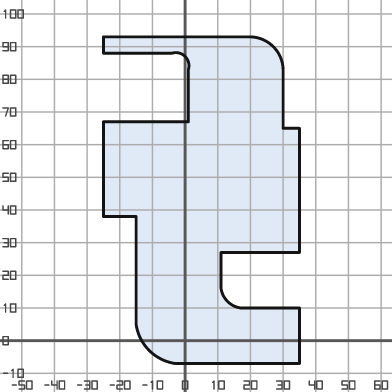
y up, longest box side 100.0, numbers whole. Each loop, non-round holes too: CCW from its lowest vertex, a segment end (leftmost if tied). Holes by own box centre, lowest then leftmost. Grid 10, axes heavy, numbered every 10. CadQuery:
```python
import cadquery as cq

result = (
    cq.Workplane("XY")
    .moveTo(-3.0, -7.0)
    .lineTo(35.0, -7.0)
    .lineTo(35.0, 10.0)
    .lineTo(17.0, 10.0)
    .threePointArc((13.0, 12.0), (11.0, 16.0))
    .lineTo(11.0, 27.0)
    .lineTo(35.0, 27.0)
    .lineTo(35.0, 65.0)
    .lineTo(30.0, 65.0)
    .lineTo(30.0, 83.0)
    .threePointArc((27.0, 90.0), (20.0, 93.0))
    .lineTo(-25.0, 93.0)
    .lineTo(-25.0, 88.0)
    .lineTo(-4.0, 88.0)
    .threePointArc((0.0, 87.0), (1.0, 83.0))
    .lineTo(1.0, 67.0)
    .lineTo(-25.0, 67.0)
    .lineTo(-25.0, 38.0)
    .lineTo(-15.0, 38.0)
    .lineTo(-15.0, 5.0)
    .threePointArc((-11.0, -3.0), (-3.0, -7.0))
    .close()
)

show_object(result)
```